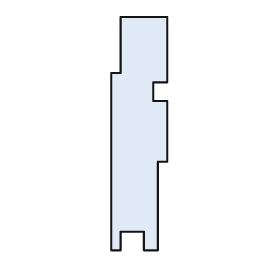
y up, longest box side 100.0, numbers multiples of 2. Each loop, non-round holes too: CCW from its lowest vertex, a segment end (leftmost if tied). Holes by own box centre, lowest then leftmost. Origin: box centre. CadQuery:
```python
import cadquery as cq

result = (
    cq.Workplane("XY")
    .moveTo(-12.0, -50.0)
    .lineTo(-8.0, -50.0)
    .lineTo(-8.0, -42.0)
    .lineTo(2.0, -42.0)
    .lineTo(2.0, -50.0)
    .lineTo(8.0, -50.0)
    .lineTo(8.0, -12.0)
    .lineTo(12.0, -12.0)
    .lineTo(12.0, 14.0)
    .lineTo(6.0, 14.0)
    .lineTo(6.0, 22.0)
    .lineTo(12.0, 22.0)
    .lineTo(12.0, 50.0)
    .lineTo(-8.0, 50.0)
    .lineTo(-8.0, 26.0)
    .lineTo(-12.0, 26.0)
    .close()
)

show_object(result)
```